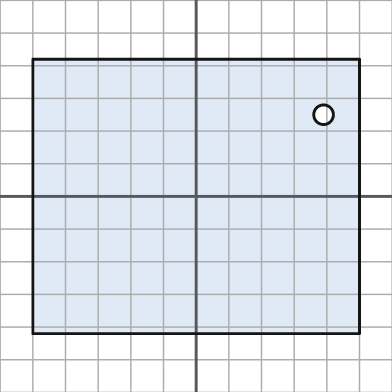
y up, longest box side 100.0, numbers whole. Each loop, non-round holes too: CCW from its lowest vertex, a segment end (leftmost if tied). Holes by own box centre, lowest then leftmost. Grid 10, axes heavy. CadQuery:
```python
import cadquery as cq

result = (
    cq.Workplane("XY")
    .moveTo(-50.0, -42.0)
    .lineTo(50.0, -42.0)
    .lineTo(50.0, 42.0)
    .lineTo(-50.0, 42.0)
    .close()
    .moveTo(39.0, 25.0)
    .circle(3.0)
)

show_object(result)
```